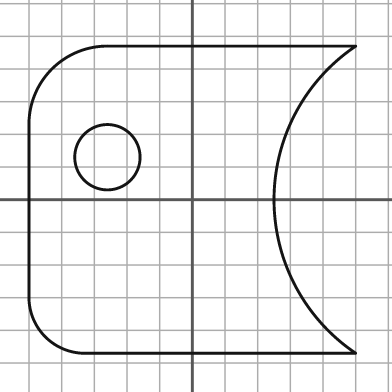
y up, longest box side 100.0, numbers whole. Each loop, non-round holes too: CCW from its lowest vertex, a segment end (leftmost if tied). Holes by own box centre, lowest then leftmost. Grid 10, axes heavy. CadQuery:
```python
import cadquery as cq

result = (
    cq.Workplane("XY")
    .moveTo(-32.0, -47.0)
    .lineTo(50.0, -47.0)
    .threePointArc((25.0, 0.0), (50.0, 47.0))
    .lineTo(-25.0, 47.0)
    .threePointArc((-43.0, 40.0), (-50.0, 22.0))
    .lineTo(-50.0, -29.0)
    .threePointArc((-45.0, -42.0), (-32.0, -47.0))
    .close()
    .moveTo(-26.0, 13.0)
    .circle(10.0)
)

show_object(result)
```